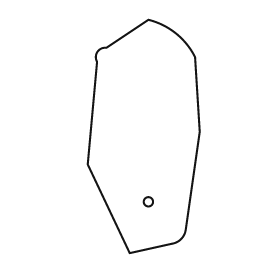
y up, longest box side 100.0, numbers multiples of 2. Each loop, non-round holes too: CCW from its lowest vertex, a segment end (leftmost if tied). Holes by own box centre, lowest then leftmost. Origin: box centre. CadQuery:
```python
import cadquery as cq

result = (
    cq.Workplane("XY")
    .moveTo(-6.0, -50.0)
    .lineTo(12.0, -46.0)
    .threePointArc((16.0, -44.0), (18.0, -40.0))
    .lineTo(24.0, 2.0)
    .lineTo(22.0, 34.0)
    .threePointArc((14.0, 44.0), (2.0, 50.0))
    .lineTo(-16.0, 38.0)
    .threePointArc((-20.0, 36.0), (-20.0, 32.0))
    .lineTo(-24.0, -12.0)
    .close()
    .moveTo(2.0, -28.0)
    .circle(2.0)
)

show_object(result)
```